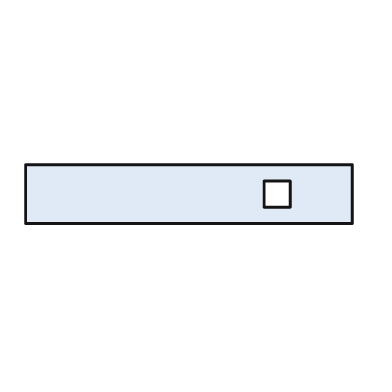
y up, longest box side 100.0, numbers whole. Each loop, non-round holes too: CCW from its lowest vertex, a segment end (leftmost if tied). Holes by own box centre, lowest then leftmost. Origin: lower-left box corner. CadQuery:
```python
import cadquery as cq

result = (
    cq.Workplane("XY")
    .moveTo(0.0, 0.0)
    .lineTo(100.0, 0.0)
    .lineTo(100.0, 18.0)
    .lineTo(0.0, 18.0)
    .close()
    .moveTo(73.0, 5.0)
    .lineTo(81.0, 5.0)
    .lineTo(81.0, 13.0)
    .lineTo(73.0, 13.0)
    .close()
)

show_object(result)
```